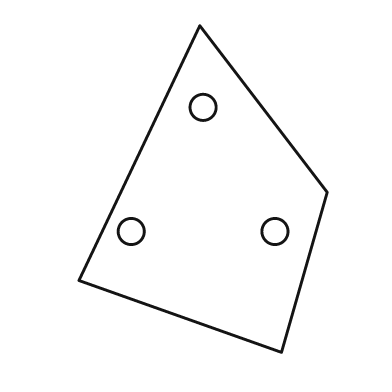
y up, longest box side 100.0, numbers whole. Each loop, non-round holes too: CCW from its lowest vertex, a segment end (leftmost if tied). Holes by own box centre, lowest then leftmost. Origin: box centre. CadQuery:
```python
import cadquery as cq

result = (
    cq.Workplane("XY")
    .moveTo(24.0, -50.0)
    .lineTo(38.0, -1.0)
    .lineTo(-1.0, 50.0)
    .lineTo(-38.0, -28.0)
    .close()
    .moveTo(-22.0, -13.0)
    .circle(4.0)
    .moveTo(22.0, -13.0)
    .circle(4.0)
    .moveTo(0.0, 25.0)
    .circle(4.0)
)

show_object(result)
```